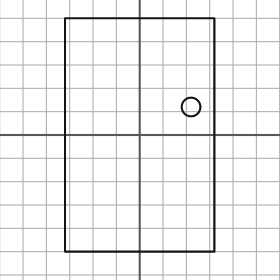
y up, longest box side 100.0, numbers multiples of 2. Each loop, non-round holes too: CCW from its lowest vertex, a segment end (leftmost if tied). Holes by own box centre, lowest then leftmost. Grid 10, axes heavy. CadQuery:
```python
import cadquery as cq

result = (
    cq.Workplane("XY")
    .moveTo(-32.0, -50.0)
    .lineTo(32.0, -50.0)
    .lineTo(32.0, 50.0)
    .lineTo(-32.0, 50.0)
    .close()
    .moveTo(22.0, 12.0)
    .circle(4.0)
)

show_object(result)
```